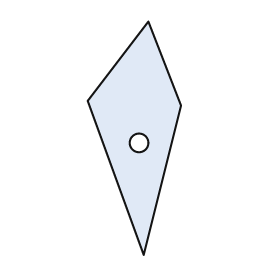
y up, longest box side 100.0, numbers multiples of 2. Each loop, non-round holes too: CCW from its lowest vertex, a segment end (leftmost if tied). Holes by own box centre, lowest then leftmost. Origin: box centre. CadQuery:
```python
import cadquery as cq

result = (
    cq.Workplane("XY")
    .moveTo(4.0, -50.0)
    .lineTo(20.0, 14.0)
    .lineTo(6.0, 50.0)
    .lineTo(-20.0, 16.0)
    .close()
    .moveTo(2.0, -2.0)
    .circle(4.0)
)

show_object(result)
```